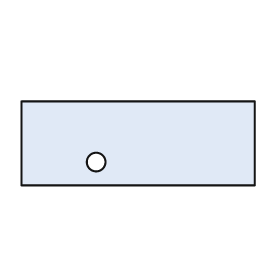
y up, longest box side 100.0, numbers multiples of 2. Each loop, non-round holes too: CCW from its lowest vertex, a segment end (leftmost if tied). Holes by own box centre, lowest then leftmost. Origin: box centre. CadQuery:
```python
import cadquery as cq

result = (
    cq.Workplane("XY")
    .moveTo(-50.0, -18.0)
    .lineTo(50.0, -18.0)
    .lineTo(50.0, 18.0)
    .lineTo(-50.0, 18.0)
    .close()
    .moveTo(-18.0, -8.0)
    .circle(4.0)
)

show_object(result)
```